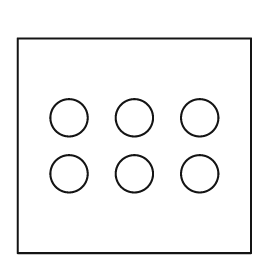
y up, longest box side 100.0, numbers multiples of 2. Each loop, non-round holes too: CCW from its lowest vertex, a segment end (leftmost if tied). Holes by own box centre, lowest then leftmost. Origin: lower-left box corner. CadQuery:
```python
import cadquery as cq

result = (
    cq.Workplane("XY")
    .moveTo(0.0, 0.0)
    .lineTo(100.0, 0.0)
    .lineTo(100.0, 92.0)
    .lineTo(0.0, 92.0)
    .close()
    .moveTo(22.0, 34.0)
    .circle(8.0)
    .moveTo(50.0, 34.0)
    .circle(8.0)
    .moveTo(78.0, 34.0)
    .circle(8.0)
    .moveTo(22.0, 58.0)
    .circle(8.0)
    .moveTo(50.0, 58.0)
    .circle(8.0)
    .moveTo(78.0, 58.0)
    .circle(8.0)
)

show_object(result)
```